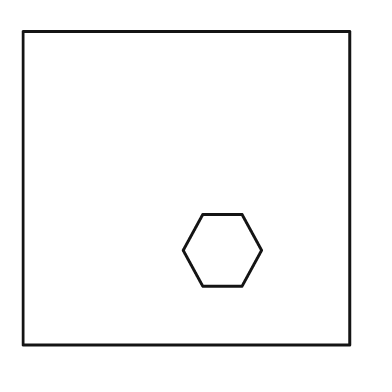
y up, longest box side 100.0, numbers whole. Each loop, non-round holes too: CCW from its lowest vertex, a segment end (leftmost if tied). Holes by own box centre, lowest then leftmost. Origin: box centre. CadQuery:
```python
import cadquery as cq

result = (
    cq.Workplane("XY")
    .moveTo(-50.0, -48.0)
    .lineTo(50.0, -48.0)
    .lineTo(50.0, 48.0)
    .lineTo(-50.0, 48.0)
    .close()
    .moveTo(5.0, -30.0)
    .lineTo(17.0, -30.0)
    .lineTo(23.0, -19.0)
    .lineTo(17.0, -8.0)
    .lineTo(5.0, -8.0)
    .lineTo(-1.0, -19.0)
    .close()
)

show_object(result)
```